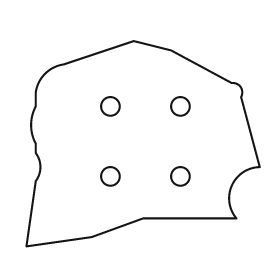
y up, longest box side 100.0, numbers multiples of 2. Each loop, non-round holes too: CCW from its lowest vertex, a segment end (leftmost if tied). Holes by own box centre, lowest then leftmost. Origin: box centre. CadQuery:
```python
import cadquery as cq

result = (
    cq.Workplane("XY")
    .moveTo(-50.0, -44.0)
    .lineTo(-22.0, -40.0)
    .lineTo(0.0, -32.0)
    .lineTo(40.0, -32.0)
    .threePointArc((38.0, -18.0), (50.0, -10.0))
    .lineTo(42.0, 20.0)
    .threePointArc((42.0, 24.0), (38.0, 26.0))
    .lineTo(12.0, 40.0)
    .lineTo(-4.0, 44.0)
    .lineTo(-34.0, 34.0)
    .threePointArc((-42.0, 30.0), (-46.0, 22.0))
    .lineTo(-46.0, 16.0)
    .threePointArc((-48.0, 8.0), (-46.0, 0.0))
    .lineTo(-46.0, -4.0)
    .threePointArc((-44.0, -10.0), (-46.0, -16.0))
    .close()
    .moveTo(-14.0, -14.0)
    .circle(4.0)
    .moveTo(16.0, -14.0)
    .circle(4.0)
    .moveTo(-14.0, 16.0)
    .circle(4.0)
    .moveTo(16.0, 16.0)
    .circle(4.0)
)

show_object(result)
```